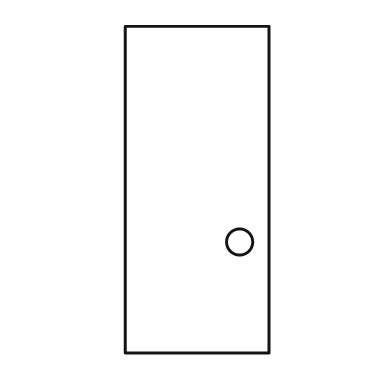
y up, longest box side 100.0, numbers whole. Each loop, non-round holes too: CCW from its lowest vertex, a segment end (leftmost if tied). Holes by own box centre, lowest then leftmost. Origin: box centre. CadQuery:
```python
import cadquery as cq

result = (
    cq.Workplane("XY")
    .moveTo(-22.0, -50.0)
    .lineTo(22.0, -50.0)
    .lineTo(22.0, 50.0)
    .lineTo(-22.0, 50.0)
    .close()
    .moveTo(13.0, -16.0)
    .circle(4.0)
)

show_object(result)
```